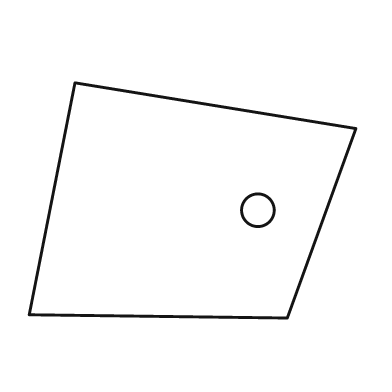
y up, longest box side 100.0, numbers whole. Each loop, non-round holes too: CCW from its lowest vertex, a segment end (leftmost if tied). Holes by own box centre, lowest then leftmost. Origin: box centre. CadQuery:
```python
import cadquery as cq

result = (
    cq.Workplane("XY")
    .moveTo(29.0, -36.0)
    .lineTo(50.0, 22.0)
    .lineTo(-36.0, 36.0)
    .lineTo(-50.0, -35.0)
    .close()
    .moveTo(20.0, -3.0)
    .circle(5.0)
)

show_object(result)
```